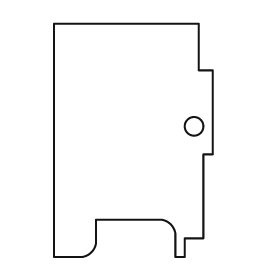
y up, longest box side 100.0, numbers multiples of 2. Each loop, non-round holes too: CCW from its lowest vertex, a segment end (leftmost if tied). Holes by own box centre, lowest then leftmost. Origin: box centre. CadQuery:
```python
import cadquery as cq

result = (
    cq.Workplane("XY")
    .moveTo(-34.0, -50.0)
    .lineTo(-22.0, -50.0)
    .threePointArc((-18.0, -48.0), (-16.0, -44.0))
    .lineTo(-16.0, -34.0)
    .lineTo(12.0, -34.0)
    .threePointArc((16.0, -36.0), (18.0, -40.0))
    .lineTo(18.0, -50.0)
    .lineTo(22.0, -50.0)
    .lineTo(22.0, -42.0)
    .lineTo(30.0, -42.0)
    .lineTo(30.0, -6.0)
    .lineTo(34.0, -6.0)
    .lineTo(34.0, 30.0)
    .lineTo(28.0, 30.0)
    .lineTo(28.0, 50.0)
    .lineTo(-34.0, 50.0)
    .close()
    .moveTo(26.0, 6.0)
    .circle(4.0)
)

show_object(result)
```